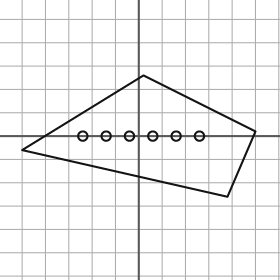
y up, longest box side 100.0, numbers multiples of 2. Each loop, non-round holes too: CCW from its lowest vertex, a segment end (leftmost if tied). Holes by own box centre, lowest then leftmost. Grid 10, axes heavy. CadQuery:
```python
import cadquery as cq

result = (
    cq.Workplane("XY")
    .moveTo(38.0, -26.0)
    .lineTo(50.0, 2.0)
    .lineTo(2.0, 26.0)
    .lineTo(-50.0, -6.0)
    .close()
    .moveTo(-24.0, 0.0)
    .circle(2.0)
    .moveTo(-14.0, 0.0)
    .circle(2.0)
    .moveTo(-4.0, 0.0)
    .circle(2.0)
    .moveTo(6.0, 0.0)
    .circle(2.0)
    .moveTo(16.0, 0.0)
    .circle(2.0)
    .moveTo(26.0, 0.0)
    .circle(2.0)
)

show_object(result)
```